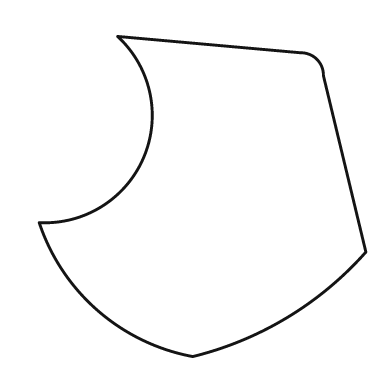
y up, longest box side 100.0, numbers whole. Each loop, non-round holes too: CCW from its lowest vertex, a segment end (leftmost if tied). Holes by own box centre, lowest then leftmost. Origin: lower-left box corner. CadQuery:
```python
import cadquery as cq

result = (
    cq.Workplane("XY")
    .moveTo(47.0, 0.0)
    .threePointArc((76.0, 12.0), (100.0, 32.0))
    .lineTo(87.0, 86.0)
    .threePointArc((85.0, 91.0), (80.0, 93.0))
    .lineTo(24.0, 98.0)
    .threePointArc((32.0, 61.0), (0.0, 41.0))
    .threePointArc((18.0, 14.0), (47.0, 0.0))
    .close()
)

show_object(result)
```